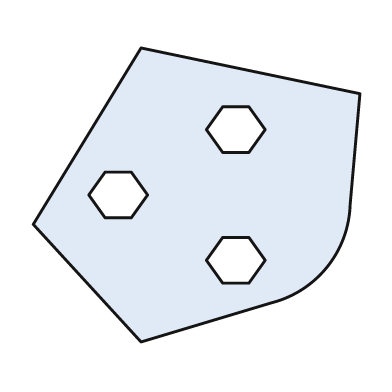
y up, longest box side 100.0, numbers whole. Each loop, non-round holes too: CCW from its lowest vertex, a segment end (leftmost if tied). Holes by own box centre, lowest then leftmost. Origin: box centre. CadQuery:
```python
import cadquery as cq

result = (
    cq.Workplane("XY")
    .moveTo(-17.0, -45.0)
    .lineTo(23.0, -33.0)
    .threePointArc((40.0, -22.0), (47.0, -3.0))
    .lineTo(50.0, 31.0)
    .lineTo(-17.0, 45.0)
    .lineTo(-50.0, -9.0)
    .close()
    .moveTo(8.0, -27.0)
    .lineTo(16.0, -27.0)
    .lineTo(21.0, -20.0)
    .lineTo(16.0, -13.0)
    .lineTo(8.0, -13.0)
    .lineTo(3.0, -20.0)
    .close()
    .moveTo(-28.0, -7.0)
    .lineTo(-20.0, -7.0)
    .lineTo(-15.0, 0.0)
    .lineTo(-20.0, 7.0)
    .lineTo(-28.0, 7.0)
    .lineTo(-33.0, 0.0)
    .close()
    .moveTo(8.0, 13.0)
    .lineTo(16.0, 13.0)
    .lineTo(21.0, 20.0)
    .lineTo(16.0, 27.0)
    .lineTo(8.0, 27.0)
    .lineTo(3.0, 20.0)
    .close()
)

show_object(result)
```